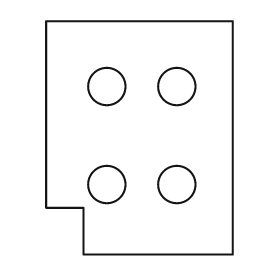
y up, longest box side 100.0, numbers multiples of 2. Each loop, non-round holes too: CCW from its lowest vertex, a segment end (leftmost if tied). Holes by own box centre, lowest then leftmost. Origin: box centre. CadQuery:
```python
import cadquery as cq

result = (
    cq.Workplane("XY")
    .moveTo(-24.0, -50.0)
    .lineTo(40.0, -50.0)
    .lineTo(40.0, 50.0)
    .lineTo(-40.0, 50.0)
    .lineTo(-40.0, -30.0)
    .lineTo(-24.0, -30.0)
    .close()
    .moveTo(-14.0, -20.0)
    .circle(8.0)
    .moveTo(16.0, -20.0)
    .circle(8.0)
    .moveTo(-14.0, 22.0)
    .circle(8.0)
    .moveTo(16.0, 22.0)
    .circle(8.0)
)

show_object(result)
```